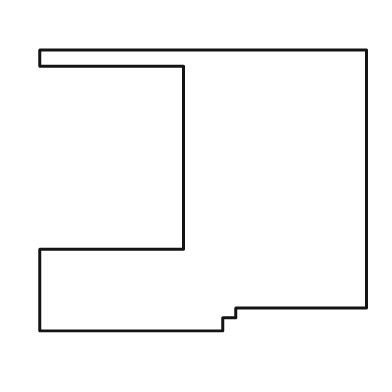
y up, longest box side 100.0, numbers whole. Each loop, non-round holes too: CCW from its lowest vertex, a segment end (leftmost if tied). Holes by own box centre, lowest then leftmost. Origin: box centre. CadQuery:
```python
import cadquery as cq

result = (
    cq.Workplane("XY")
    .moveTo(-50.0, -43.0)
    .lineTo(6.0, -43.0)
    .lineTo(6.0, -39.0)
    .lineTo(10.0, -39.0)
    .lineTo(10.0, -36.0)
    .lineTo(50.0, -36.0)
    .lineTo(50.0, 43.0)
    .lineTo(-50.0, 43.0)
    .lineTo(-50.0, 38.0)
    .lineTo(-6.0, 38.0)
    .lineTo(-6.0, -18.0)
    .lineTo(-50.0, -18.0)
    .close()
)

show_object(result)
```